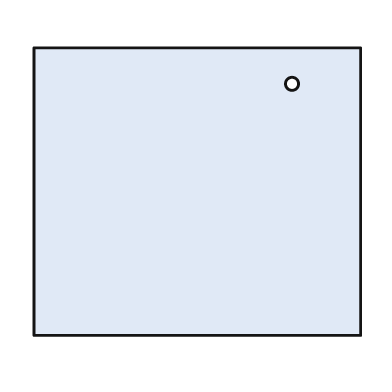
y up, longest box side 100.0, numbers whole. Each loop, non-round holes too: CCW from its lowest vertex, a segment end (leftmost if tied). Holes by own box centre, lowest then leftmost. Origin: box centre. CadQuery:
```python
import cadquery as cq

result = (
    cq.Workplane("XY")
    .moveTo(-50.0, -44.0)
    .lineTo(50.0, -44.0)
    .lineTo(50.0, 44.0)
    .lineTo(-50.0, 44.0)
    .close()
    .moveTo(29.0, 33.0)
    .circle(2.0)
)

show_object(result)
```